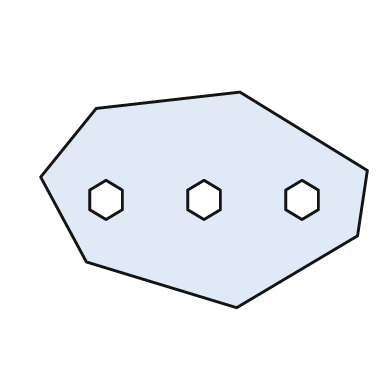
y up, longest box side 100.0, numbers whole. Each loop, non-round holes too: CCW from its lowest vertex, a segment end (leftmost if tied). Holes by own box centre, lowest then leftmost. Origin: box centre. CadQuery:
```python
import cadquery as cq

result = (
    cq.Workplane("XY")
    .moveTo(10.0, -33.0)
    .lineTo(47.0, -11.0)
    .lineTo(50.0, 9.0)
    .lineTo(11.0, 33.0)
    .lineTo(-33.0, 28.0)
    .lineTo(-50.0, 7.0)
    .lineTo(-36.0, -19.0)
    .close()
    .moveTo(-30.0, -6.0)
    .lineTo(-25.0, -3.0)
    .lineTo(-25.0, 3.0)
    .lineTo(-30.0, 6.0)
    .lineTo(-35.0, 3.0)
    .lineTo(-35.0, -3.0)
    .close()
    .moveTo(0.0, -6.0)
    .lineTo(5.0, -3.0)
    .lineTo(5.0, 3.0)
    .lineTo(0.0, 6.0)
    .lineTo(-5.0, 3.0)
    .lineTo(-5.0, -3.0)
    .close()
    .moveTo(30.0, -6.0)
    .lineTo(35.0, -3.0)
    .lineTo(35.0, 3.0)
    .lineTo(30.0, 6.0)
    .lineTo(25.0, 3.0)
    .lineTo(25.0, -3.0)
    .close()
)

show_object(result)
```